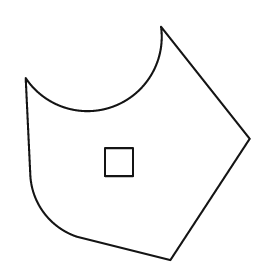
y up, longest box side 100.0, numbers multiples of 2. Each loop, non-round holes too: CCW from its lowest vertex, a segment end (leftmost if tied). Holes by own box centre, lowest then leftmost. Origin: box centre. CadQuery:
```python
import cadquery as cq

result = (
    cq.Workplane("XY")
    .moveTo(14.0, -50.0)
    .lineTo(48.0, 2.0)
    .lineTo(10.0, 50.0)
    .threePointArc((-10.0, 16.0), (-48.0, 28.0))
    .lineTo(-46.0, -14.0)
    .threePointArc((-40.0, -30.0), (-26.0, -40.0))
    .close()
    .moveTo(-14.0, -14.0)
    .lineTo(-2.0, -14.0)
    .lineTo(-2.0, -2.0)
    .lineTo(-14.0, -2.0)
    .close()
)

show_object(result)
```